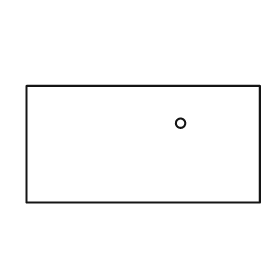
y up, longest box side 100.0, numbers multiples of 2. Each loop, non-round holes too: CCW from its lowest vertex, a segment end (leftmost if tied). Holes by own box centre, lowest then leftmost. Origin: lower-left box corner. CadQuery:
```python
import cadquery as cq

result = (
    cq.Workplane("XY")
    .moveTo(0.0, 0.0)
    .lineTo(100.0, 0.0)
    .lineTo(100.0, 50.0)
    .lineTo(0.0, 50.0)
    .close()
    .moveTo(66.0, 34.0)
    .circle(2.0)
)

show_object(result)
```